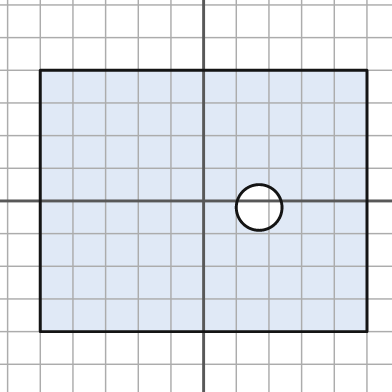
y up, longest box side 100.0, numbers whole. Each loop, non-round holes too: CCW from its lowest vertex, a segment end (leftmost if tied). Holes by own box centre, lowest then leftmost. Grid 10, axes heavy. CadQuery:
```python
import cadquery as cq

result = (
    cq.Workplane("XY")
    .moveTo(-50.0, -40.0)
    .lineTo(50.0, -40.0)
    .lineTo(50.0, 40.0)
    .lineTo(-50.0, 40.0)
    .close()
    .moveTo(17.0, -2.0)
    .circle(7.0)
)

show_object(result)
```